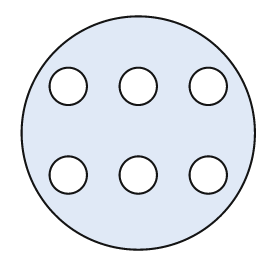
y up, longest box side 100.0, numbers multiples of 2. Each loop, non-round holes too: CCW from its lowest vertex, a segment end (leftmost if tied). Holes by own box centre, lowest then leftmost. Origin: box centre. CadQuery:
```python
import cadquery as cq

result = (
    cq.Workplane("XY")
    .moveTo(0.0, 0.0)
    .circle(50.0)
    .moveTo(-30.0, -18.0)
    .circle(8.0)
    .moveTo(0.0, -18.0)
    .circle(8.0)
    .moveTo(30.0, -18.0)
    .circle(8.0)
    .moveTo(-30.0, 20.0)
    .circle(8.0)
    .moveTo(0.0, 20.0)
    .circle(8.0)
    .moveTo(30.0, 20.0)
    .circle(8.0)
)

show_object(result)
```